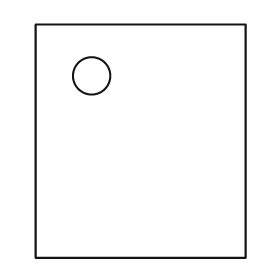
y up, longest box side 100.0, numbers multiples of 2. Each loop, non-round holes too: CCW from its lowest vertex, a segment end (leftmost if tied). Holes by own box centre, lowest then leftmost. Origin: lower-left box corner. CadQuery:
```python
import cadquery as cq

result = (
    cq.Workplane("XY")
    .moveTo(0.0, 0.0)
    .lineTo(90.0, 0.0)
    .lineTo(90.0, 100.0)
    .lineTo(0.0, 100.0)
    .close()
    .moveTo(24.0, 78.0)
    .circle(8.0)
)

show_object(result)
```